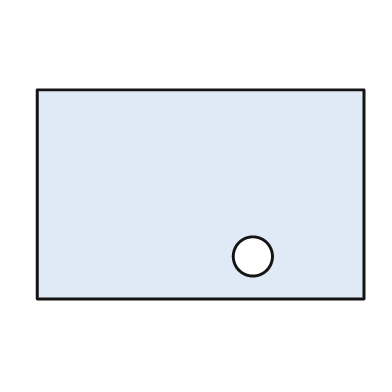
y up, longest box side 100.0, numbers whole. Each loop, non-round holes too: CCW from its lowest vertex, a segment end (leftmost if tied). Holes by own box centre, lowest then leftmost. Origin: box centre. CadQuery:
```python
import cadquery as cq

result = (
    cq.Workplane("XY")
    .moveTo(-50.0, -32.0)
    .lineTo(50.0, -32.0)
    .lineTo(50.0, 32.0)
    .lineTo(-50.0, 32.0)
    .close()
    .moveTo(16.0, -19.0)
    .circle(6.0)
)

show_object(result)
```